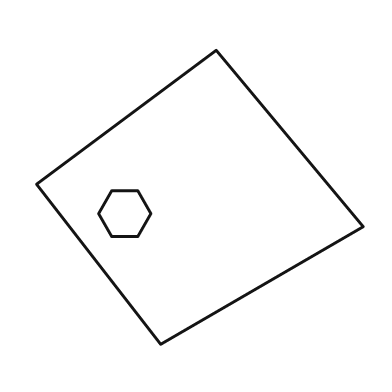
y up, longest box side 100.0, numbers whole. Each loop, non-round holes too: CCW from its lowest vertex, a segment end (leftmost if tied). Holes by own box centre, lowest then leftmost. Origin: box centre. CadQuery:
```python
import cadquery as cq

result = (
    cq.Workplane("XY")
    .moveTo(-12.0, -45.0)
    .lineTo(50.0, -9.0)
    .lineTo(5.0, 45.0)
    .lineTo(-50.0, 4.0)
    .close()
    .moveTo(-27.0, -12.0)
    .lineTo(-19.0, -12.0)
    .lineTo(-15.0, -5.0)
    .lineTo(-19.0, 2.0)
    .lineTo(-27.0, 2.0)
    .lineTo(-31.0, -5.0)
    .close()
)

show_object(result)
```